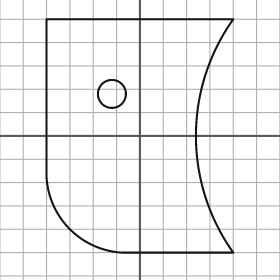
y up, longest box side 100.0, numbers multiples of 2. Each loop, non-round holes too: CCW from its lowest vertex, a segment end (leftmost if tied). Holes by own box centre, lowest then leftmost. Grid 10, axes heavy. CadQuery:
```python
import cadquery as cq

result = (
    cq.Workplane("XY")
    .moveTo(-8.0, -50.0)
    .lineTo(40.0, -50.0)
    .threePointArc((24.0, 0.0), (40.0, 50.0))
    .lineTo(-40.0, 50.0)
    .lineTo(-40.0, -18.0)
    .threePointArc((-30.0, -40.0), (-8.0, -50.0))
    .close()
    .moveTo(-12.0, 18.0)
    .circle(6.0)
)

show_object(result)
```